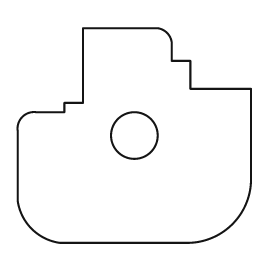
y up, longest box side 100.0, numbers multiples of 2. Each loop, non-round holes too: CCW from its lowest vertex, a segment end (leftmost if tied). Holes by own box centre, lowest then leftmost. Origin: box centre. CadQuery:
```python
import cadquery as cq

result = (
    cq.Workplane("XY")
    .moveTo(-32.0, -46.0)
    .lineTo(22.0, -46.0)
    .threePointArc((42.0, -38.0), (50.0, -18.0))
    .lineTo(50.0, 20.0)
    .lineTo(24.0, 20.0)
    .lineTo(24.0, 32.0)
    .lineTo(16.0, 32.0)
    .lineTo(16.0, 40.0)
    .threePointArc((14.0, 44.0), (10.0, 46.0))
    .lineTo(-22.0, 46.0)
    .lineTo(-22.0, 14.0)
    .lineTo(-30.0, 14.0)
    .lineTo(-30.0, 10.0)
    .lineTo(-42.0, 10.0)
    .threePointArc((-48.0, 8.0), (-50.0, 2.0))
    .lineTo(-50.0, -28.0)
    .threePointArc((-44.0, -40.0), (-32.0, -46.0))
    .close()
    .moveTo(0.0, 0.0)
    .circle(10.0)
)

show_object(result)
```